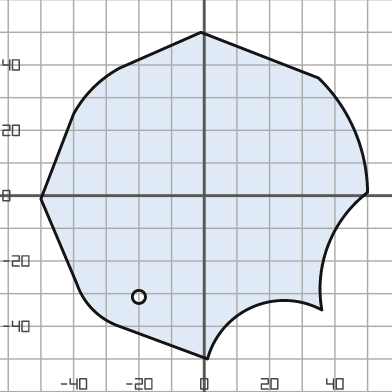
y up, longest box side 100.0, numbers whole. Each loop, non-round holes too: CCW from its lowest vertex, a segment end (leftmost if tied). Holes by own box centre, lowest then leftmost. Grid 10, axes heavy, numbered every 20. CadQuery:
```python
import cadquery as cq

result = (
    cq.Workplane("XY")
    .moveTo(1.0, -50.0)
    .threePointArc((15.0, -34.0), (36.0, -35.0))
    .threePointArc((38.0, -15.0), (50.0, 1.0))
    .threePointArc((46.0, 20.0), (35.0, 36.0))
    .lineTo(-1.0, 50.0)
    .lineTo(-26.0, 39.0)
    .threePointArc((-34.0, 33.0), (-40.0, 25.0))
    .lineTo(-50.0, -1.0)
    .lineTo(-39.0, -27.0)
    .threePointArc((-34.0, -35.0), (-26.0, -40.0))
    .close()
    .moveTo(-20.0, -31.0)
    .circle(2.0)
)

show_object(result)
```